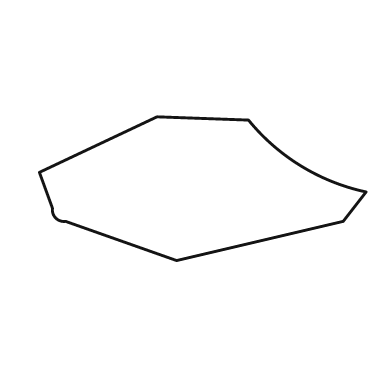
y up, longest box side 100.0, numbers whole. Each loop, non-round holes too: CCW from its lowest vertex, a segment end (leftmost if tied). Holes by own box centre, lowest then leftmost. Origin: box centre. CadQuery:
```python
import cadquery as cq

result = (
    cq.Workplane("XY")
    .moveTo(-8.0, -22.0)
    .lineTo(43.0, -10.0)
    .lineTo(50.0, -1.0)
    .threePointArc((30.0, 7.0), (14.0, 21.0))
    .lineTo(-14.0, 22.0)
    .lineTo(-50.0, 5.0)
    .lineTo(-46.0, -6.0)
    .threePointArc((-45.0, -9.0), (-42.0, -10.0))
    .close()
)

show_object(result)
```